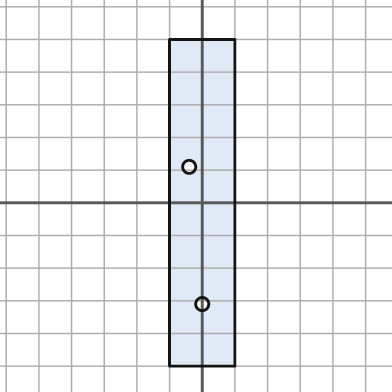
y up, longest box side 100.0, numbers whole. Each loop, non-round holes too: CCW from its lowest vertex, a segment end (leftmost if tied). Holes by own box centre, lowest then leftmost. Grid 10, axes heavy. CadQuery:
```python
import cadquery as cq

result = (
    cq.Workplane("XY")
    .moveTo(-10.0, -50.0)
    .lineTo(10.0, -50.0)
    .lineTo(10.0, 50.0)
    .lineTo(-10.0, 50.0)
    .close()
    .moveTo(0.0, -31.0)
    .circle(2.0)
    .moveTo(-4.0, 11.0)
    .circle(2.0)
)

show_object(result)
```